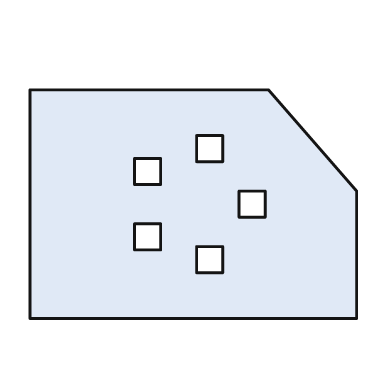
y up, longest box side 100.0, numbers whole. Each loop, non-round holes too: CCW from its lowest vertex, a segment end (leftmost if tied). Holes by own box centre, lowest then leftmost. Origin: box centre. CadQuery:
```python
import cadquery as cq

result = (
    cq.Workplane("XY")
    .moveTo(-50.0, -35.0)
    .lineTo(50.0, -35.0)
    .lineTo(50.0, 4.0)
    .lineTo(23.0, 35.0)
    .lineTo(-50.0, 35.0)
    .close()
    .moveTo(1.0, -21.0)
    .lineTo(9.0, -21.0)
    .lineTo(9.0, -13.0)
    .lineTo(1.0, -13.0)
    .close()
    .moveTo(-18.0, -14.0)
    .lineTo(-10.0, -14.0)
    .lineTo(-10.0, -6.0)
    .lineTo(-18.0, -6.0)
    .close()
    .moveTo(14.0, -4.0)
    .lineTo(22.0, -4.0)
    .lineTo(22.0, 4.0)
    .lineTo(14.0, 4.0)
    .close()
    .moveTo(-18.0, 6.0)
    .lineTo(-10.0, 6.0)
    .lineTo(-10.0, 14.0)
    .lineTo(-18.0, 14.0)
    .close()
    .moveTo(1.0, 13.0)
    .lineTo(9.0, 13.0)
    .lineTo(9.0, 21.0)
    .lineTo(1.0, 21.0)
    .close()
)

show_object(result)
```